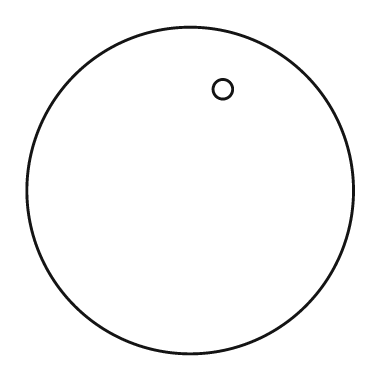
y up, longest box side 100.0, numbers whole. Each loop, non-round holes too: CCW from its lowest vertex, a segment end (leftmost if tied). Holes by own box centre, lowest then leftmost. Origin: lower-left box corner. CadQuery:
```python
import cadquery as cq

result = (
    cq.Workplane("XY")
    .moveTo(50.0, 50.0)
    .circle(50.0)
    .moveTo(60.0, 81.0)
    .circle(3.0)
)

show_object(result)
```